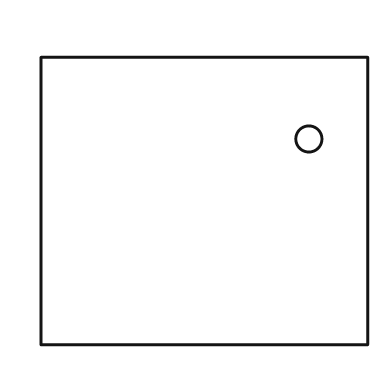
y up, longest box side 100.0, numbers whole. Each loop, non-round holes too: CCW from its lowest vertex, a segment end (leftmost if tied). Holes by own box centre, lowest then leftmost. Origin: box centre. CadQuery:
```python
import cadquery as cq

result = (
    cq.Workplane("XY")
    .moveTo(-50.0, -44.0)
    .lineTo(50.0, -44.0)
    .lineTo(50.0, 44.0)
    .lineTo(-50.0, 44.0)
    .close()
    .moveTo(32.0, 19.0)
    .circle(4.0)
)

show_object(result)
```